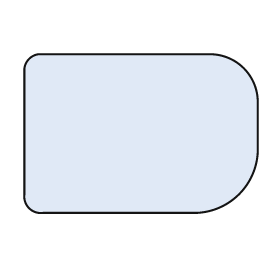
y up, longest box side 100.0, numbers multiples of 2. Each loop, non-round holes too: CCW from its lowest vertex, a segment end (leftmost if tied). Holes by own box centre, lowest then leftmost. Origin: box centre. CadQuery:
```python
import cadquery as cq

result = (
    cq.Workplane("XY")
    .moveTo(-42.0, -34.0)
    .lineTo(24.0, -34.0)
    .threePointArc((42.0, -26.0), (50.0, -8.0))
    .lineTo(50.0, 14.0)
    .threePointArc((44.0, 28.0), (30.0, 34.0))
    .lineTo(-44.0, 34.0)
    .threePointArc((-48.0, 32.0), (-50.0, 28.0))
    .lineTo(-50.0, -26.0)
    .threePointArc((-48.0, -32.0), (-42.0, -34.0))
    .close()
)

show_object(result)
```